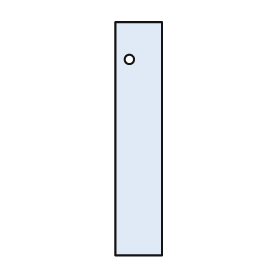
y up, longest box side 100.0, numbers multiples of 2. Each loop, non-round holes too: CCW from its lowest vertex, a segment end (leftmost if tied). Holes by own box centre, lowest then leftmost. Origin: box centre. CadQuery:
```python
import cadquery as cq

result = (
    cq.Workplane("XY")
    .moveTo(-10.0, -50.0)
    .lineTo(10.0, -50.0)
    .lineTo(10.0, 50.0)
    .lineTo(-10.0, 50.0)
    .close()
    .moveTo(-4.0, 34.0)
    .circle(2.0)
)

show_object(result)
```